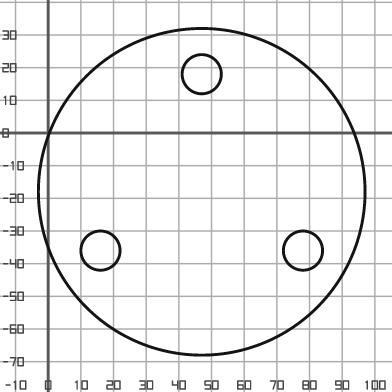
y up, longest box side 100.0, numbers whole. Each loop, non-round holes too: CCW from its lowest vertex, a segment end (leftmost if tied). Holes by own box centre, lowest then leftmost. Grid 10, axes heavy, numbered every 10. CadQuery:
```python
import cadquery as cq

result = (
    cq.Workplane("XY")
    .moveTo(47.0, -18.0)
    .circle(50.0)
    .moveTo(16.0, -36.0)
    .circle(6.0)
    .moveTo(78.0, -36.0)
    .circle(6.0)
    .moveTo(47.0, 18.0)
    .circle(6.0)
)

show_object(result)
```